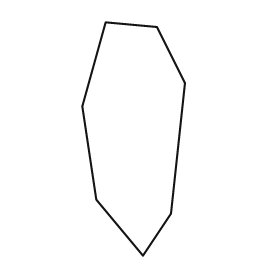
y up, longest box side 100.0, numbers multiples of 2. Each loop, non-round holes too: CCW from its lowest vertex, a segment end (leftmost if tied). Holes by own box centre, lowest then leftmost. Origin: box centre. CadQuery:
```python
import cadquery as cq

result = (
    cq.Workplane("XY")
    .moveTo(4.0, -50.0)
    .lineTo(16.0, -32.0)
    .lineTo(22.0, 24.0)
    .lineTo(10.0, 48.0)
    .lineTo(-12.0, 50.0)
    .lineTo(-22.0, 14.0)
    .lineTo(-16.0, -26.0)
    .close()
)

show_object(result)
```